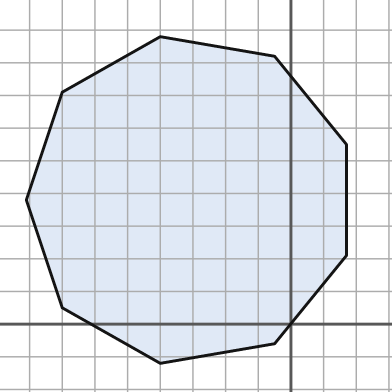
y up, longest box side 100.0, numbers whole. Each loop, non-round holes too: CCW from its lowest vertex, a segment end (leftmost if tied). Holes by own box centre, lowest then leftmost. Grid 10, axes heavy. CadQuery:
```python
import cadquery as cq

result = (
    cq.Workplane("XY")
    .moveTo(-40.0, -12.0)
    .lineTo(-5.0, -6.0)
    .lineTo(17.0, 21.0)
    .lineTo(17.0, 55.0)
    .lineTo(-5.0, 82.0)
    .lineTo(-40.0, 88.0)
    .lineTo(-70.0, 71.0)
    .lineTo(-81.0, 38.0)
    .lineTo(-70.0, 5.0)
    .close()
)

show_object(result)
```